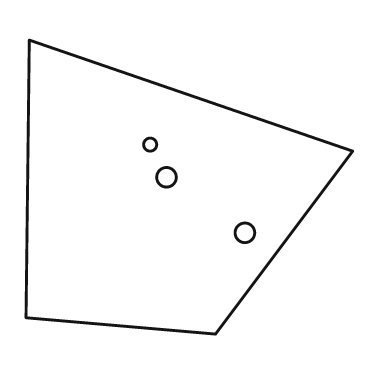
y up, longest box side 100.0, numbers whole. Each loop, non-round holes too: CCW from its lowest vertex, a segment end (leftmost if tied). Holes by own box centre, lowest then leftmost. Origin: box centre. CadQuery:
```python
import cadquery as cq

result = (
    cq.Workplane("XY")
    .moveTo(8.0, -45.0)
    .lineTo(50.0, 11.0)
    .lineTo(-49.0, 45.0)
    .lineTo(-50.0, -40.0)
    .close()
    .moveTo(17.0, -14.0)
    .circle(3.0)
    .moveTo(-7.0, 3.0)
    .circle(3.0)
    .moveTo(-12.0, 13.0)
    .circle(2.0)
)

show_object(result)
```